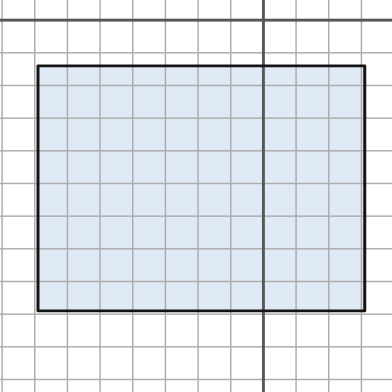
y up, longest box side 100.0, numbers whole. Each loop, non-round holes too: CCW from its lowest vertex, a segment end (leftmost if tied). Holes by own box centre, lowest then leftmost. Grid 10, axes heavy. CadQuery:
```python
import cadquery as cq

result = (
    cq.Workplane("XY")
    .moveTo(-69.0, -89.0)
    .lineTo(31.0, -89.0)
    .lineTo(31.0, -14.0)
    .lineTo(-69.0, -14.0)
    .close()
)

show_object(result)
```